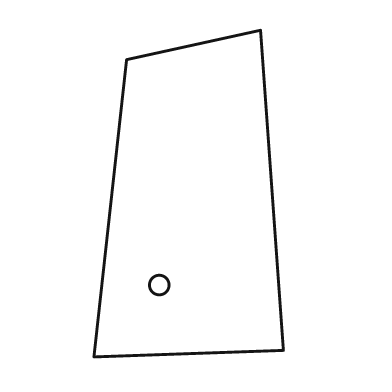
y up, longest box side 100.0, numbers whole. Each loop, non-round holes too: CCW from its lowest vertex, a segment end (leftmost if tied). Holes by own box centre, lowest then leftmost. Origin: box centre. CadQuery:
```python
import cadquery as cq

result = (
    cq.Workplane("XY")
    .moveTo(-29.0, -50.0)
    .lineTo(29.0, -48.0)
    .lineTo(22.0, 50.0)
    .lineTo(-19.0, 41.0)
    .close()
    .moveTo(-9.0, -28.0)
    .circle(3.0)
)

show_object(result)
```